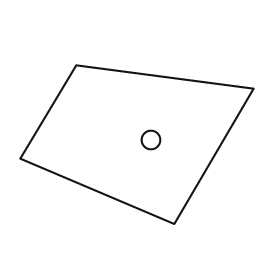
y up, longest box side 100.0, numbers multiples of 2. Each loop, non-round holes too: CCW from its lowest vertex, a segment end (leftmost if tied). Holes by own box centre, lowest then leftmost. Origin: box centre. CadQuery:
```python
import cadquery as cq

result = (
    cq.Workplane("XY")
    .moveTo(16.0, -34.0)
    .lineTo(50.0, 24.0)
    .lineTo(-26.0, 34.0)
    .lineTo(-50.0, -6.0)
    .close()
    .moveTo(6.0, 2.0)
    .circle(4.0)
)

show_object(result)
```